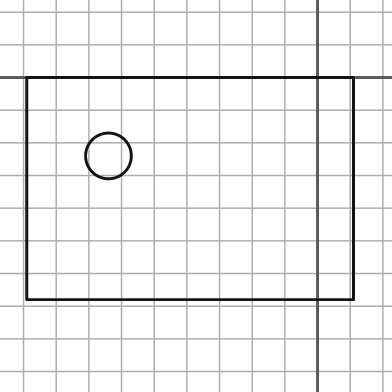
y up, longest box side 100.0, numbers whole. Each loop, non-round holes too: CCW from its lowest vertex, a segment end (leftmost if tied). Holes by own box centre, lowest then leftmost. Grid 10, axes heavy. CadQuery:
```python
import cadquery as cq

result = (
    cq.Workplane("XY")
    .moveTo(-89.0, -68.0)
    .lineTo(11.0, -68.0)
    .lineTo(11.0, 0.0)
    .lineTo(-89.0, 0.0)
    .close()
    .moveTo(-64.0, -24.0)
    .circle(7.0)
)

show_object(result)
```